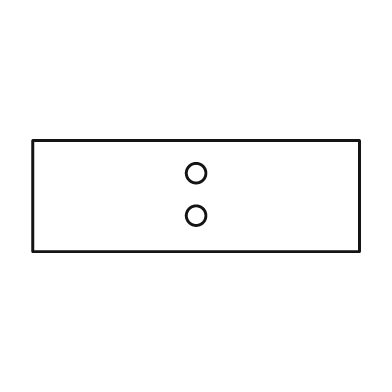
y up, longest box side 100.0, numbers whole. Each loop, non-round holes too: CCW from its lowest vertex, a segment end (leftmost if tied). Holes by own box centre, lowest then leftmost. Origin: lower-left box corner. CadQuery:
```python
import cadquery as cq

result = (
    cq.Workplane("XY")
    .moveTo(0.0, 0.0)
    .lineTo(100.0, 0.0)
    .lineTo(100.0, 34.0)
    .lineTo(0.0, 34.0)
    .close()
    .moveTo(50.0, 11.0)
    .circle(3.0)
    .moveTo(50.0, 24.0)
    .circle(3.0)
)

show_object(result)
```